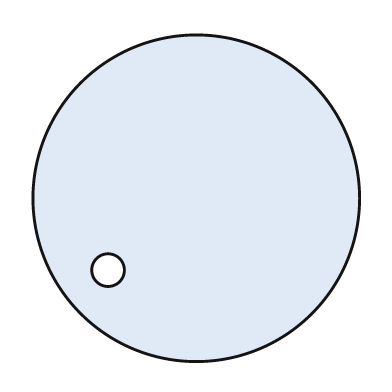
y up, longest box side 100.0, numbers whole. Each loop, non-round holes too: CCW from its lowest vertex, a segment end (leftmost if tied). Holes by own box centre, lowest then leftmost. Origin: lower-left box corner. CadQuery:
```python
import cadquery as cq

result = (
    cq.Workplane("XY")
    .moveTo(50.0, 50.0)
    .circle(50.0)
    .moveTo(23.0, 28.0)
    .circle(5.0)
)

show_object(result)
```